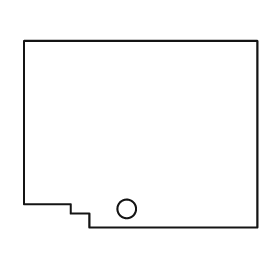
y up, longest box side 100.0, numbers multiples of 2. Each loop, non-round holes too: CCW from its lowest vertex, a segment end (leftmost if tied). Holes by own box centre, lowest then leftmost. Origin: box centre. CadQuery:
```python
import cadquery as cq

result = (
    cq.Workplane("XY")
    .moveTo(-22.0, -40.0)
    .lineTo(50.0, -40.0)
    .lineTo(50.0, 40.0)
    .lineTo(-50.0, 40.0)
    .lineTo(-50.0, -30.0)
    .lineTo(-30.0, -30.0)
    .lineTo(-30.0, -34.0)
    .lineTo(-22.0, -34.0)
    .close()
    .moveTo(-6.0, -32.0)
    .circle(4.0)
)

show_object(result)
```